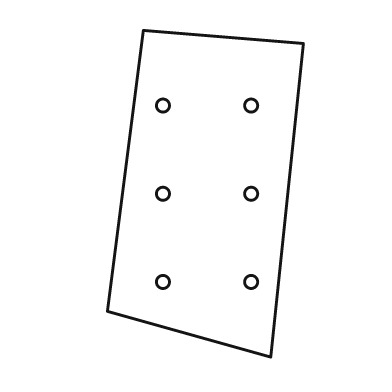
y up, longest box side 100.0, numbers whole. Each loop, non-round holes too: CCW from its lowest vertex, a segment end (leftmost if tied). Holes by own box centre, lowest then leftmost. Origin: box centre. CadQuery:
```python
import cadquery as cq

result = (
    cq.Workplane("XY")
    .moveTo(20.0, -50.0)
    .lineTo(30.0, 46.0)
    .lineTo(-19.0, 50.0)
    .lineTo(-30.0, -36.0)
    .close()
    .moveTo(-13.0, -27.0)
    .circle(2.0)
    .moveTo(14.0, -27.0)
    .circle(2.0)
    .moveTo(-13.0, 0.0)
    .circle(2.0)
    .moveTo(14.0, 0.0)
    .circle(2.0)
    .moveTo(-13.0, 27.0)
    .circle(2.0)
    .moveTo(14.0, 27.0)
    .circle(2.0)
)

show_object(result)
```